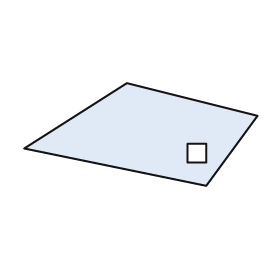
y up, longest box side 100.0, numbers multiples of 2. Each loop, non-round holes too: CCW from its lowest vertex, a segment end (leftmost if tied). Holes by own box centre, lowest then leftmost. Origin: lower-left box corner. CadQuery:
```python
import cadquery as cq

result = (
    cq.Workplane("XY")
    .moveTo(78.0, 0.0)
    .lineTo(100.0, 30.0)
    .lineTo(44.0, 44.0)
    .lineTo(0.0, 16.0)
    .close()
    .moveTo(70.0, 10.0)
    .lineTo(78.0, 10.0)
    .lineTo(78.0, 18.0)
    .lineTo(70.0, 18.0)
    .close()
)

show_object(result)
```